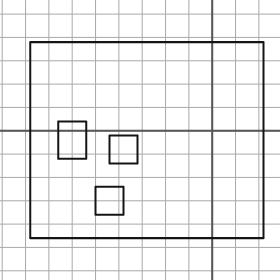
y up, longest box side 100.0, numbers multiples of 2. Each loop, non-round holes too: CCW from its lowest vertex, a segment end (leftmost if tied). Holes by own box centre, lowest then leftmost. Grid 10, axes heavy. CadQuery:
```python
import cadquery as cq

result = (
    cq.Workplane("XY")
    .moveTo(-78.0, -46.0)
    .lineTo(22.0, -46.0)
    .lineTo(22.0, 38.0)
    .lineTo(-78.0, 38.0)
    .close()
    .moveTo(-50.0, -36.0)
    .lineTo(-38.0, -36.0)
    .lineTo(-38.0, -24.0)
    .lineTo(-50.0, -24.0)
    .close()
    .moveTo(-44.0, -14.0)
    .lineTo(-32.0, -14.0)
    .lineTo(-32.0, -2.0)
    .lineTo(-44.0, -2.0)
    .close()
    .moveTo(-66.0, -12.0)
    .lineTo(-54.0, -12.0)
    .lineTo(-54.0, 4.0)
    .lineTo(-66.0, 4.0)
    .close()
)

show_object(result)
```